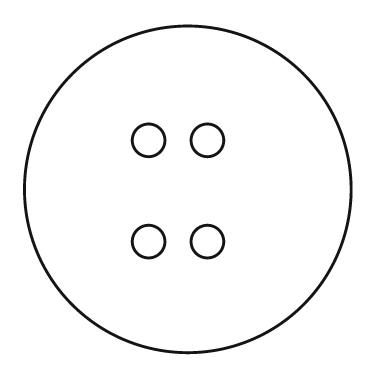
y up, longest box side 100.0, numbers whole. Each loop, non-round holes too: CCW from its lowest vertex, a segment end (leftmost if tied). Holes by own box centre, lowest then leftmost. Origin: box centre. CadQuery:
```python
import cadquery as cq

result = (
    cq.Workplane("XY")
    .moveTo(0.0, 0.0)
    .circle(50.0)
    .moveTo(-12.0, -16.0)
    .circle(5.0)
    .moveTo(6.0, -16.0)
    .circle(5.0)
    .moveTo(-12.0, 15.0)
    .circle(5.0)
    .moveTo(6.0, 15.0)
    .circle(5.0)
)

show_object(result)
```